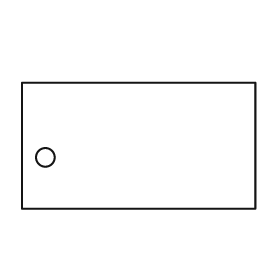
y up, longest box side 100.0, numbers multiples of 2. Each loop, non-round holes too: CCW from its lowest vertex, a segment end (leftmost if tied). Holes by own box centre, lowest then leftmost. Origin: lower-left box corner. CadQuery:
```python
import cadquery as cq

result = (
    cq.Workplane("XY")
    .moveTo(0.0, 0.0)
    .lineTo(100.0, 0.0)
    .lineTo(100.0, 54.0)
    .lineTo(0.0, 54.0)
    .close()
    .moveTo(10.0, 22.0)
    .circle(4.0)
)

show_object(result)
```